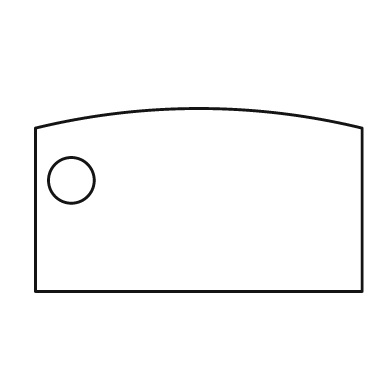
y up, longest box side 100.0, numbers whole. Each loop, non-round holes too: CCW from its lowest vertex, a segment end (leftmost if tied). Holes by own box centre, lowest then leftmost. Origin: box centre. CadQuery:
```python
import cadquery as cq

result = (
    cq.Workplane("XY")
    .moveTo(-50.0, -28.0)
    .lineTo(50.0, -28.0)
    .lineTo(50.0, 22.0)
    .threePointArc((0.0, 28.0), (-50.0, 22.0))
    .close()
    .moveTo(-39.0, 6.0)
    .circle(7.0)
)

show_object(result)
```